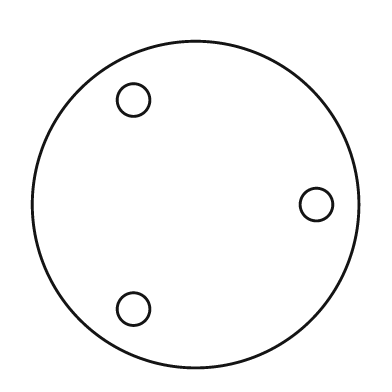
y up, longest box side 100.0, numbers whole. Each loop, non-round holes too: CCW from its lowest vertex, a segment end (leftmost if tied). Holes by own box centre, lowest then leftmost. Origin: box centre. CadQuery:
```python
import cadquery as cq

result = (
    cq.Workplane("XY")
    .moveTo(0.0, 0.0)
    .circle(50.0)
    .moveTo(-19.0, -32.0)
    .circle(5.0)
    .moveTo(37.0, 0.0)
    .circle(5.0)
    .moveTo(-19.0, 32.0)
    .circle(5.0)
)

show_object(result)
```